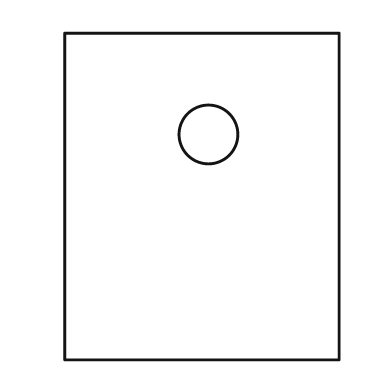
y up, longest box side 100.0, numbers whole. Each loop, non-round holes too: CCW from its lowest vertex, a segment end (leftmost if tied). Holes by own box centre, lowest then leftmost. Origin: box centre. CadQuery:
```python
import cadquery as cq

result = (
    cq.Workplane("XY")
    .moveTo(-42.0, -50.0)
    .lineTo(42.0, -50.0)
    .lineTo(42.0, 50.0)
    .lineTo(-42.0, 50.0)
    .close()
    .moveTo(2.0, 19.0)
    .circle(9.0)
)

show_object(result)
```